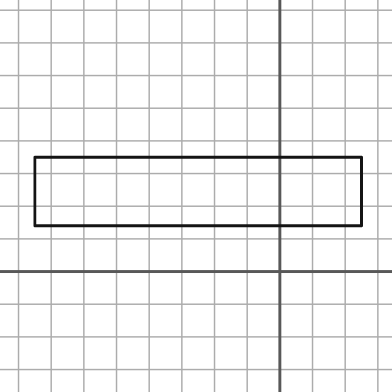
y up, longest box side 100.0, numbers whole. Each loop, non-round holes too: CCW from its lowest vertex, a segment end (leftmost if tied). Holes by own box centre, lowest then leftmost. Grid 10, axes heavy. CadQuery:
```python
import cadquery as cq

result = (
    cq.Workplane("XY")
    .moveTo(-75.0, 14.0)
    .lineTo(25.0, 14.0)
    .lineTo(25.0, 35.0)
    .lineTo(-75.0, 35.0)
    .close()
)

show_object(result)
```